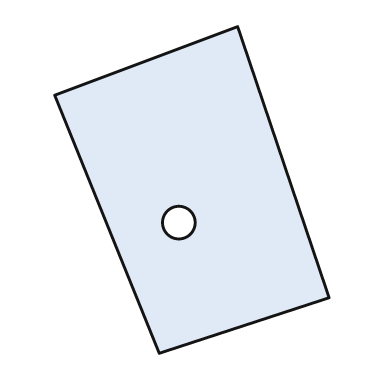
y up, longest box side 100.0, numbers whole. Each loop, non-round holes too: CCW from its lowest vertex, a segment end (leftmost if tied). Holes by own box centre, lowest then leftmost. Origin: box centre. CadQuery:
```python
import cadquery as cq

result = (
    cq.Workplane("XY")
    .moveTo(-10.0, -50.0)
    .lineTo(42.0, -33.0)
    .lineTo(14.0, 50.0)
    .lineTo(-42.0, 29.0)
    .close()
    .moveTo(-4.0, -10.0)
    .circle(5.0)
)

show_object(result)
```